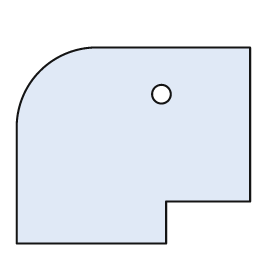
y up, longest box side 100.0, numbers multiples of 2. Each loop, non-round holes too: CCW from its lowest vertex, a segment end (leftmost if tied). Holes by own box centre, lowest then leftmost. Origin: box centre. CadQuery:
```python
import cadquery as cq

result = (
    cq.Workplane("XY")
    .moveTo(-50.0, -42.0)
    .lineTo(14.0, -42.0)
    .lineTo(14.0, -24.0)
    .lineTo(50.0, -24.0)
    .lineTo(50.0, 42.0)
    .lineTo(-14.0, 42.0)
    .threePointArc((-40.0, 32.0), (-50.0, 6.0))
    .close()
    .moveTo(12.0, 22.0)
    .circle(4.0)
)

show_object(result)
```